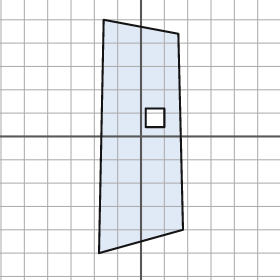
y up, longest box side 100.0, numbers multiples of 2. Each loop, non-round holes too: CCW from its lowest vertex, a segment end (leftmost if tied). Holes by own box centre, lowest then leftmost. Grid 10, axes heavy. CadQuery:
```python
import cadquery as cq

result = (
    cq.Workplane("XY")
    .moveTo(-18.0, -50.0)
    .lineTo(18.0, -40.0)
    .lineTo(16.0, 44.0)
    .lineTo(-16.0, 50.0)
    .close()
    .moveTo(2.0, 4.0)
    .lineTo(10.0, 4.0)
    .lineTo(10.0, 12.0)
    .lineTo(2.0, 12.0)
    .close()
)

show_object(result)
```